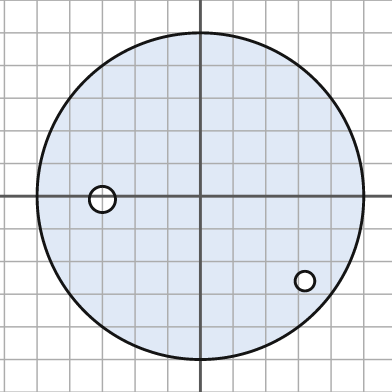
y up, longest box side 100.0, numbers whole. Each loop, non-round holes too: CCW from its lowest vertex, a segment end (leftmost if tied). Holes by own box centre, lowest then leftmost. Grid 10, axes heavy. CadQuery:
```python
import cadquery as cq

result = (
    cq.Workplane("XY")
    .moveTo(0.0, 0.0)
    .circle(50.0)
    .moveTo(32.0, -26.0)
    .circle(3.0)
    .moveTo(-30.0, -1.0)
    .circle(4.0)
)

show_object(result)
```